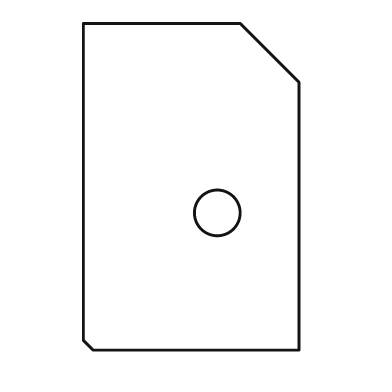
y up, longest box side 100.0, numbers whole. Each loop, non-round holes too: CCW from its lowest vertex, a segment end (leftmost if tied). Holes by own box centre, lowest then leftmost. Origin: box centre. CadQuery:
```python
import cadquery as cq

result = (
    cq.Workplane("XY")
    .moveTo(-30.0, -50.0)
    .lineTo(33.0, -50.0)
    .lineTo(33.0, 32.0)
    .lineTo(15.0, 50.0)
    .lineTo(-33.0, 50.0)
    .lineTo(-33.0, -47.0)
    .close()
    .moveTo(8.0, -8.0)
    .circle(7.0)
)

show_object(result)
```